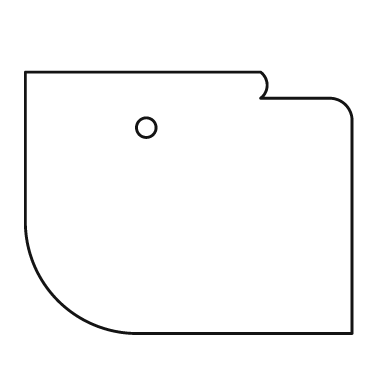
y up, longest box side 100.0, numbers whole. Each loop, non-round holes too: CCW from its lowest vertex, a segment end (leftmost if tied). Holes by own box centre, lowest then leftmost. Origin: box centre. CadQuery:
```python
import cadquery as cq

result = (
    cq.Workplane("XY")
    .moveTo(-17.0, -40.0)
    .lineTo(50.0, -40.0)
    .lineTo(50.0, 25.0)
    .threePointArc((48.0, 30.0), (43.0, 32.0))
    .lineTo(22.0, 32.0)
    .threePointArc((24.0, 36.0), (22.0, 40.0))
    .lineTo(-50.0, 40.0)
    .lineTo(-50.0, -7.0)
    .threePointArc((-40.0, -30.0), (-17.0, -40.0))
    .close()
    .moveTo(-13.0, 23.0)
    .circle(3.0)
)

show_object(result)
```